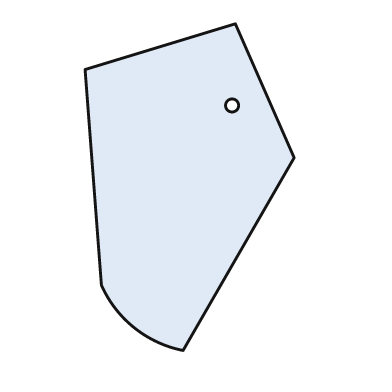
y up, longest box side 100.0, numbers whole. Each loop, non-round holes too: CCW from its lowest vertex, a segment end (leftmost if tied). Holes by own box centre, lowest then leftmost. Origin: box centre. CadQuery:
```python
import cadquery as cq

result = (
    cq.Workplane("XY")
    .moveTo(-2.0, -50.0)
    .lineTo(32.0, 9.0)
    .lineTo(14.0, 50.0)
    .lineTo(-32.0, 36.0)
    .lineTo(-27.0, -30.0)
    .threePointArc((-17.0, -43.0), (-2.0, -50.0))
    .close()
    .moveTo(13.0, 25.0)
    .circle(2.0)
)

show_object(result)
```